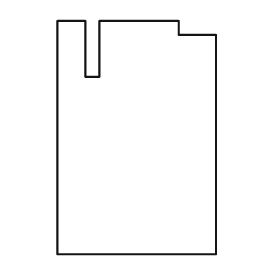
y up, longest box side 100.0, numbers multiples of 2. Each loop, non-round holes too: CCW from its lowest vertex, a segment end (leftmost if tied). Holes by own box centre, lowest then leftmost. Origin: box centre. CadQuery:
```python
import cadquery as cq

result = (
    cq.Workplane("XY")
    .moveTo(-34.0, -50.0)
    .lineTo(34.0, -50.0)
    .lineTo(34.0, 44.0)
    .lineTo(18.0, 44.0)
    .lineTo(18.0, 50.0)
    .lineTo(-16.0, 50.0)
    .lineTo(-16.0, 26.0)
    .lineTo(-22.0, 26.0)
    .lineTo(-22.0, 50.0)
    .lineTo(-34.0, 50.0)
    .close()
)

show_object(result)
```